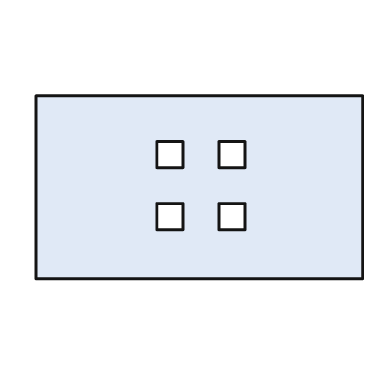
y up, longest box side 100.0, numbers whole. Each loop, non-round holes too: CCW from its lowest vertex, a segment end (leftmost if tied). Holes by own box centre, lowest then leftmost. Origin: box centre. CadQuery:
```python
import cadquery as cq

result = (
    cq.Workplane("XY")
    .moveTo(-50.0, -28.0)
    .lineTo(50.0, -28.0)
    .lineTo(50.0, 28.0)
    .lineTo(-50.0, 28.0)
    .close()
    .moveTo(-13.0, -13.0)
    .lineTo(-5.0, -13.0)
    .lineTo(-5.0, -5.0)
    .lineTo(-13.0, -5.0)
    .close()
    .moveTo(6.0, -13.0)
    .lineTo(14.0, -13.0)
    .lineTo(14.0, -5.0)
    .lineTo(6.0, -5.0)
    .close()
    .moveTo(-13.0, 6.0)
    .lineTo(-5.0, 6.0)
    .lineTo(-5.0, 14.0)
    .lineTo(-13.0, 14.0)
    .close()
    .moveTo(6.0, 6.0)
    .lineTo(14.0, 6.0)
    .lineTo(14.0, 14.0)
    .lineTo(6.0, 14.0)
    .close()
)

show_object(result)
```